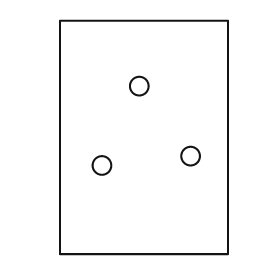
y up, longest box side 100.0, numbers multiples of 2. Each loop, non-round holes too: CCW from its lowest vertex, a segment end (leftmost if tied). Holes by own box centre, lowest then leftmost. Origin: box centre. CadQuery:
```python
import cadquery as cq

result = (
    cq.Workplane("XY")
    .moveTo(-36.0, -50.0)
    .lineTo(36.0, -50.0)
    .lineTo(36.0, 50.0)
    .lineTo(-36.0, 50.0)
    .close()
    .moveTo(-18.0, -12.0)
    .circle(4.0)
    .moveTo(20.0, -8.0)
    .circle(4.0)
    .moveTo(-2.0, 22.0)
    .circle(4.0)
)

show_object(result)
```